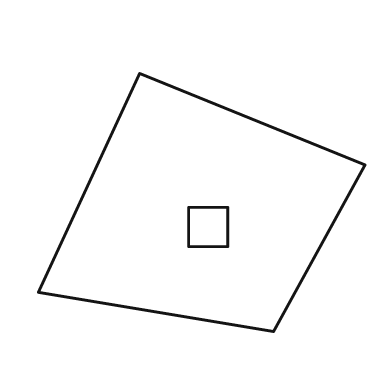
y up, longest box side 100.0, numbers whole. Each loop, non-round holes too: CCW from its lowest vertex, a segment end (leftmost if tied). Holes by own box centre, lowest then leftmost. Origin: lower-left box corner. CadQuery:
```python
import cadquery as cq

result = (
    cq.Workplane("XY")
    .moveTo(72.0, 0.0)
    .lineTo(100.0, 51.0)
    .lineTo(31.0, 79.0)
    .lineTo(0.0, 12.0)
    .close()
    .moveTo(46.0, 26.0)
    .lineTo(58.0, 26.0)
    .lineTo(58.0, 38.0)
    .lineTo(46.0, 38.0)
    .close()
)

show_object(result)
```